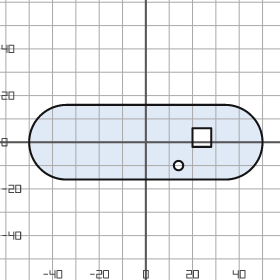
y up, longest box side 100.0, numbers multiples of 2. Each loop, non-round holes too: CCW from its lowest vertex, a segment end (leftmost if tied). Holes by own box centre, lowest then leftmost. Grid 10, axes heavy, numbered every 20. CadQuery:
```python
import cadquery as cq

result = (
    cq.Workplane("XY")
    .moveTo(-34.0, -16.0)
    .lineTo(34.0, -16.0)
    .threePointArc((50.0, 0.0), (34.0, 16.0))
    .lineTo(-34.0, 16.0)
    .threePointArc((-50.0, 0.0), (-34.0, -16.0))
    .close()
    .moveTo(14.0, -10.0)
    .circle(2.0)
    .moveTo(20.0, -2.0)
    .lineTo(28.0, -2.0)
    .lineTo(28.0, 6.0)
    .lineTo(20.0, 6.0)
    .close()
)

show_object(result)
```